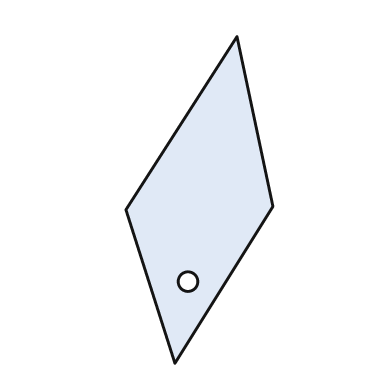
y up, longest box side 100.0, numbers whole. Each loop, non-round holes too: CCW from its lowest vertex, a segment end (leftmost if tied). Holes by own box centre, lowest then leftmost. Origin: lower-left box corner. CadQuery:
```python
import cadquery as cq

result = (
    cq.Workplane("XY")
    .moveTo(15.0, 0.0)
    .lineTo(45.0, 48.0)
    .lineTo(34.0, 100.0)
    .lineTo(0.0, 47.0)
    .close()
    .moveTo(19.0, 25.0)
    .circle(3.0)
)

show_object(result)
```